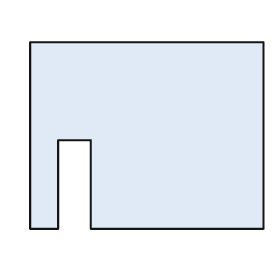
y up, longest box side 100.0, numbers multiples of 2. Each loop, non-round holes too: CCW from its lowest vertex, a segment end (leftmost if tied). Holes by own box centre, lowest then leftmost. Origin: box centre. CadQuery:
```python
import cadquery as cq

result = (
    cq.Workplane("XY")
    .moveTo(-50.0, -40.0)
    .lineTo(-38.0, -40.0)
    .lineTo(-38.0, -2.0)
    .lineTo(-24.0, -2.0)
    .lineTo(-24.0, -40.0)
    .lineTo(50.0, -40.0)
    .lineTo(50.0, 40.0)
    .lineTo(-50.0, 40.0)
    .close()
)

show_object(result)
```